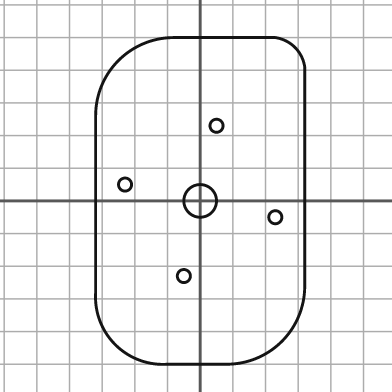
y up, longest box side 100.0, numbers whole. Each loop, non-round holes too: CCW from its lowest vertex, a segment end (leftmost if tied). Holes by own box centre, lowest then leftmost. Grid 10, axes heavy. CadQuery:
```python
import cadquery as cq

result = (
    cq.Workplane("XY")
    .moveTo(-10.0, -50.0)
    .lineTo(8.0, -50.0)
    .threePointArc((25.0, -43.0), (32.0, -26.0))
    .lineTo(32.0, 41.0)
    .threePointArc((29.0, 47.0), (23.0, 50.0))
    .lineTo(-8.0, 50.0)
    .threePointArc((-25.0, 43.0), (-32.0, 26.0))
    .lineTo(-32.0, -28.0)
    .threePointArc((-26.0, -44.0), (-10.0, -50.0))
    .close()
    .moveTo(-5.0, -23.0)
    .circle(2.0)
    .moveTo(23.0, -5.0)
    .circle(2.0)
    .moveTo(0.0, 0.0)
    .circle(5.0)
    .moveTo(-23.0, 5.0)
    .circle(2.0)
    .moveTo(5.0, 23.0)
    .circle(2.0)
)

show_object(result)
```